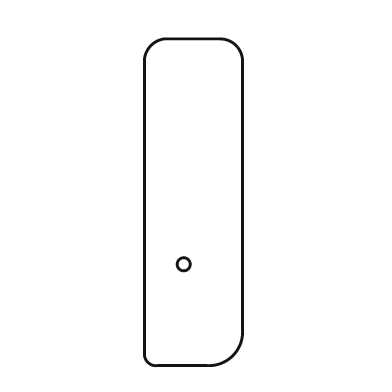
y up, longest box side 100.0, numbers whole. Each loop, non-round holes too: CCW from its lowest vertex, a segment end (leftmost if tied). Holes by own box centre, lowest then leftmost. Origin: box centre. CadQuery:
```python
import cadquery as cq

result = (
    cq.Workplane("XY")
    .moveTo(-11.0, -50.0)
    .lineTo(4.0, -50.0)
    .threePointArc((12.0, -47.0), (15.0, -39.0))
    .lineTo(15.0, 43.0)
    .threePointArc((13.0, 48.0), (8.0, 50.0))
    .lineTo(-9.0, 50.0)
    .threePointArc((-13.0, 48.0), (-15.0, 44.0))
    .lineTo(-15.0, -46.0)
    .threePointArc((-14.0, -49.0), (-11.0, -50.0))
    .close()
    .moveTo(-3.0, -19.0)
    .circle(2.0)
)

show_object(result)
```